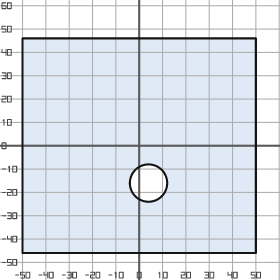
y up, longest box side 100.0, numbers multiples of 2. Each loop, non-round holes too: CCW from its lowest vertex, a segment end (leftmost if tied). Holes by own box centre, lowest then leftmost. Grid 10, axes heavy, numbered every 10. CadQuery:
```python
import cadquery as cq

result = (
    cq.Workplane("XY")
    .moveTo(-50.0, -46.0)
    .lineTo(50.0, -46.0)
    .lineTo(50.0, 46.0)
    .lineTo(-50.0, 46.0)
    .close()
    .moveTo(4.0, -16.0)
    .circle(8.0)
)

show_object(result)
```